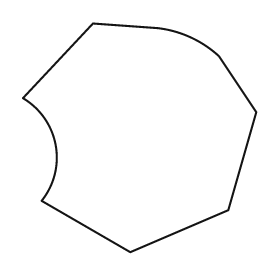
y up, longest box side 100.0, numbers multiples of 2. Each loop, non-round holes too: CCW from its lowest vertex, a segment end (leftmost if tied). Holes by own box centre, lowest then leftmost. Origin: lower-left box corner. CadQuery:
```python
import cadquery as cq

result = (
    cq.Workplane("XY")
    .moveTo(46.0, 0.0)
    .lineTo(88.0, 18.0)
    .lineTo(100.0, 60.0)
    .lineTo(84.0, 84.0)
    .threePointArc((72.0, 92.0), (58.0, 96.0))
    .lineTo(30.0, 98.0)
    .lineTo(0.0, 66.0)
    .threePointArc((14.0, 46.0), (8.0, 22.0))
    .close()
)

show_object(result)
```